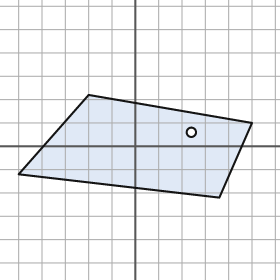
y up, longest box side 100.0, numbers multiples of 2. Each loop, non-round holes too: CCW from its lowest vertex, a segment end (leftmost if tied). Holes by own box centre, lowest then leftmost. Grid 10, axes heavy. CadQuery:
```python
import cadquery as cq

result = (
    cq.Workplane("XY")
    .moveTo(36.0, -22.0)
    .lineTo(50.0, 10.0)
    .lineTo(-20.0, 22.0)
    .lineTo(-50.0, -12.0)
    .close()
    .moveTo(24.0, 6.0)
    .circle(2.0)
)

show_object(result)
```